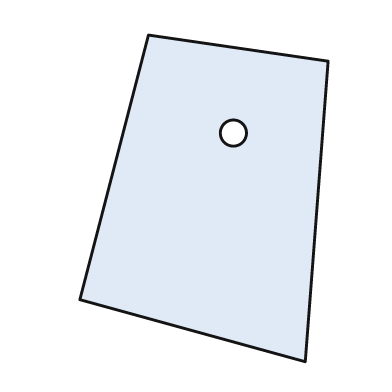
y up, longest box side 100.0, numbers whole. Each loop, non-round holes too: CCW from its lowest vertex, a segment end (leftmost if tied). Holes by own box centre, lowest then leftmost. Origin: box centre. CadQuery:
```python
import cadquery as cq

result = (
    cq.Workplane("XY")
    .moveTo(31.0, -50.0)
    .lineTo(38.0, 42.0)
    .lineTo(-17.0, 50.0)
    .lineTo(-38.0, -31.0)
    .close()
    .moveTo(9.0, 20.0)
    .circle(4.0)
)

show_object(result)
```